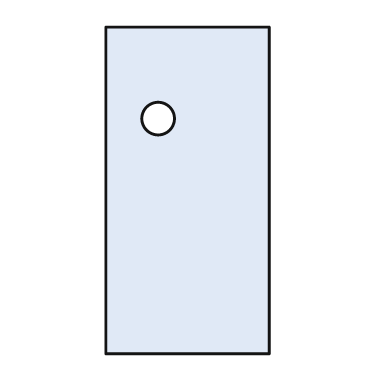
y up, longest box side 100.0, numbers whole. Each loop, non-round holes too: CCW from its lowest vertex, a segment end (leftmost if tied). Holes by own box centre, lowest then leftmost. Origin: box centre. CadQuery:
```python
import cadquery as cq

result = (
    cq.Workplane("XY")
    .moveTo(-25.0, -50.0)
    .lineTo(25.0, -50.0)
    .lineTo(25.0, 50.0)
    .lineTo(-25.0, 50.0)
    .close()
    .moveTo(-9.0, 22.0)
    .circle(5.0)
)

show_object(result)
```